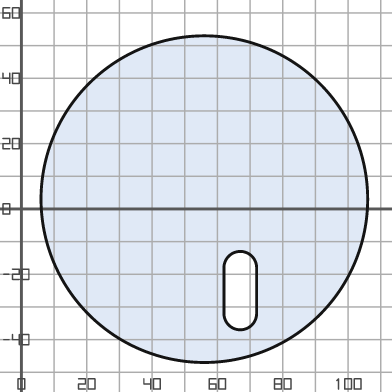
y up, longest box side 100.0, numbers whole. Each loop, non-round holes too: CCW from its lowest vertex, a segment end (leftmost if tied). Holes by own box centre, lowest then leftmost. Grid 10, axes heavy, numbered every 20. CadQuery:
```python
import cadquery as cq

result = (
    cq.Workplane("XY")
    .moveTo(56.0, 3.0)
    .circle(50.0)
    .moveTo(62.0, -32.0)
    .threePointArc((67.0, -37.0), (72.0, -32.0))
    .lineTo(72.0, -18.0)
    .threePointArc((67.0, -13.0), (62.0, -18.0))
    .close()
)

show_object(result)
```